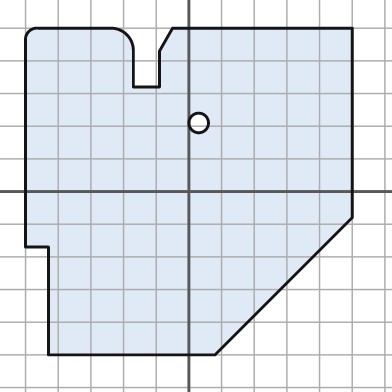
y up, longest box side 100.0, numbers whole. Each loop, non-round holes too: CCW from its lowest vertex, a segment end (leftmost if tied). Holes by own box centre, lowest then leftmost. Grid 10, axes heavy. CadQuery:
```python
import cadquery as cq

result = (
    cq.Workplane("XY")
    .moveTo(-43.0, -50.0)
    .lineTo(8.0, -50.0)
    .lineTo(50.0, -8.0)
    .lineTo(50.0, 50.0)
    .lineTo(-5.0, 50.0)
    .lineTo(-9.0, 43.0)
    .lineTo(-9.0, 32.0)
    .lineTo(-17.0, 32.0)
    .lineTo(-17.0, 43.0)
    .threePointArc((-19.0, 48.0), (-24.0, 50.0))
    .lineTo(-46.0, 50.0)
    .threePointArc((-49.0, 49.0), (-50.0, 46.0))
    .lineTo(-50.0, -17.0)
    .lineTo(-43.0, -17.0)
    .close()
    .moveTo(3.0, 21.0)
    .circle(3.0)
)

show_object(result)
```